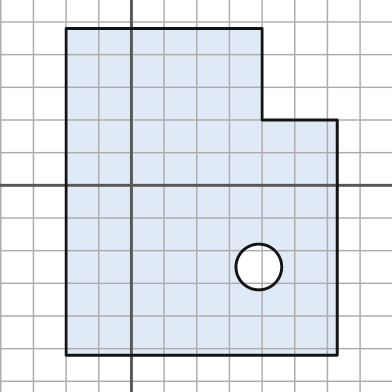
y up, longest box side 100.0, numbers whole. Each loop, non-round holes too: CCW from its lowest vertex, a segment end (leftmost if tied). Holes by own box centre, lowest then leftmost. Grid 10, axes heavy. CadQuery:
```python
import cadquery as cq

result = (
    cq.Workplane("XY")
    .moveTo(-20.0, -52.0)
    .lineTo(63.0, -52.0)
    .lineTo(63.0, 20.0)
    .lineTo(40.0, 20.0)
    .lineTo(40.0, 48.0)
    .lineTo(-20.0, 48.0)
    .close()
    .moveTo(39.0, -25.0)
    .circle(7.0)
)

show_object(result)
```